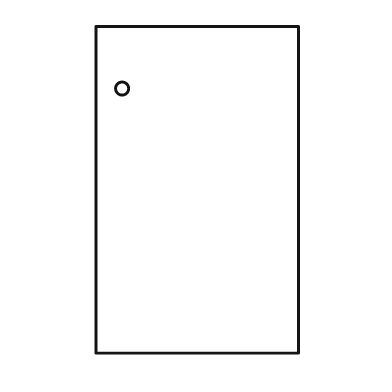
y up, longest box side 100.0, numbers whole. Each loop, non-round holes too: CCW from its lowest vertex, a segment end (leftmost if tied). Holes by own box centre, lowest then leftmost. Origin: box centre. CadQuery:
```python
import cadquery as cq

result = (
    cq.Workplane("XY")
    .moveTo(-31.0, -50.0)
    .lineTo(31.0, -50.0)
    .lineTo(31.0, 50.0)
    .lineTo(-31.0, 50.0)
    .close()
    .moveTo(-23.0, 31.0)
    .circle(2.0)
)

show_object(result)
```